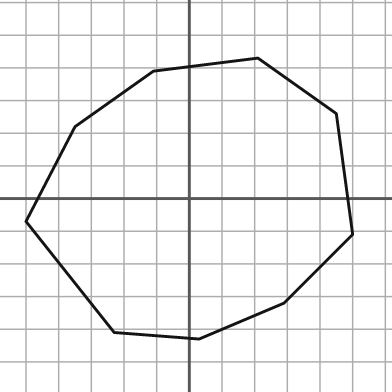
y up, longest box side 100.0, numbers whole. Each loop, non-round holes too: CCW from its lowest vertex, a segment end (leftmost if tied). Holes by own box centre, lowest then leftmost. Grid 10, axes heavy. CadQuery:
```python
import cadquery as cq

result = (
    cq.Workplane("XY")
    .moveTo(3.0, -43.0)
    .lineTo(29.0, -32.0)
    .lineTo(50.0, -11.0)
    .lineTo(45.0, 26.0)
    .lineTo(21.0, 43.0)
    .lineTo(-11.0, 39.0)
    .lineTo(-35.0, 22.0)
    .lineTo(-50.0, -7.0)
    .lineTo(-23.0, -41.0)
    .close()
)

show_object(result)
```